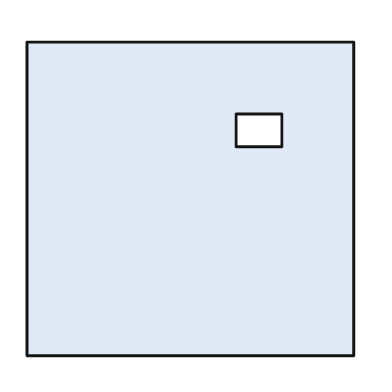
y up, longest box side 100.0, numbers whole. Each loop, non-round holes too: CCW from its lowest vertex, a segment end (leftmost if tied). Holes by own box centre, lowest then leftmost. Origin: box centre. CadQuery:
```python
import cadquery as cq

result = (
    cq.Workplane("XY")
    .moveTo(-50.0, -48.0)
    .lineTo(50.0, -48.0)
    .lineTo(50.0, 48.0)
    .lineTo(-50.0, 48.0)
    .close()
    .moveTo(14.0, 16.0)
    .lineTo(28.0, 16.0)
    .lineTo(28.0, 26.0)
    .lineTo(14.0, 26.0)
    .close()
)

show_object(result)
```